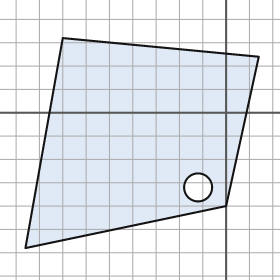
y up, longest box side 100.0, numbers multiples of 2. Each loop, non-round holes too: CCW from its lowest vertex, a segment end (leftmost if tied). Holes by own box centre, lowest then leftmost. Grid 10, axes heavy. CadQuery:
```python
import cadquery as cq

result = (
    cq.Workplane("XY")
    .moveTo(-86.0, -58.0)
    .lineTo(0.0, -40.0)
    .lineTo(14.0, 24.0)
    .lineTo(-70.0, 32.0)
    .close()
    .moveTo(-12.0, -32.0)
    .circle(6.0)
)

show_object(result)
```